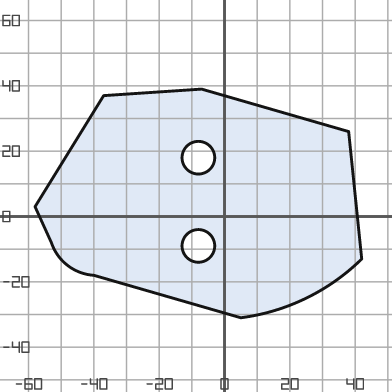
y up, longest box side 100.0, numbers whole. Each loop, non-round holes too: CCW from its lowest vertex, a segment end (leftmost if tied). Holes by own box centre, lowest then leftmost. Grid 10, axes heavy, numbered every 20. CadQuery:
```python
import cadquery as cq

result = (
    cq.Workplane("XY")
    .moveTo(5.0, -31.0)
    .threePointArc((25.0, -25.0), (42.0, -13.0))
    .lineTo(38.0, 26.0)
    .lineTo(-7.0, 39.0)
    .lineTo(-37.0, 37.0)
    .lineTo(-58.0, 3.0)
    .lineTo(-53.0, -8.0)
    .threePointArc((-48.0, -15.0), (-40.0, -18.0))
    .close()
    .moveTo(-8.0, -9.0)
    .circle(5.0)
    .moveTo(-8.0, 18.0)
    .circle(5.0)
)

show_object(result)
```